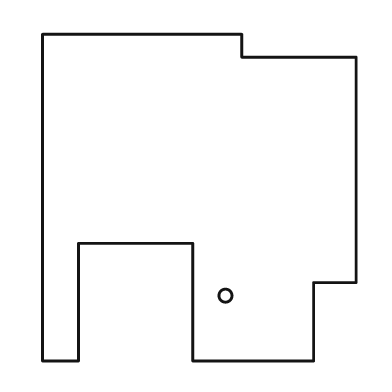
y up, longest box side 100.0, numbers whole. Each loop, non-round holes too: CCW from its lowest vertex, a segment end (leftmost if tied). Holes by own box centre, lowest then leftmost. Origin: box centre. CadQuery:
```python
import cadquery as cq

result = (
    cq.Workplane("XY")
    .moveTo(-48.0, -50.0)
    .lineTo(-37.0, -50.0)
    .lineTo(-37.0, -14.0)
    .lineTo(-2.0, -14.0)
    .lineTo(-2.0, -50.0)
    .lineTo(35.0, -50.0)
    .lineTo(35.0, -26.0)
    .lineTo(48.0, -26.0)
    .lineTo(48.0, 43.0)
    .lineTo(13.0, 43.0)
    .lineTo(13.0, 50.0)
    .lineTo(-48.0, 50.0)
    .close()
    .moveTo(8.0, -30.0)
    .circle(2.0)
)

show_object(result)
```